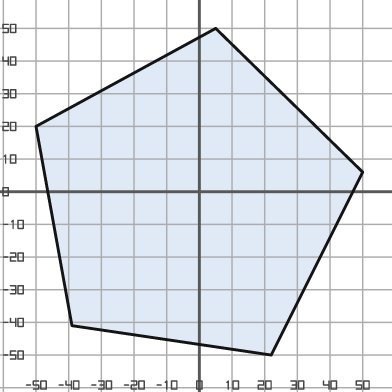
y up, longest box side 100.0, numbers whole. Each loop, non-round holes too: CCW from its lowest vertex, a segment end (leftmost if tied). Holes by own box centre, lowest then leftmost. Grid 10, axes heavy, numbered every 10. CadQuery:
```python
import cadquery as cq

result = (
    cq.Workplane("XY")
    .moveTo(22.0, -50.0)
    .lineTo(50.0, 6.0)
    .lineTo(5.0, 50.0)
    .lineTo(-50.0, 20.0)
    .lineTo(-39.0, -41.0)
    .close()
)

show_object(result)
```